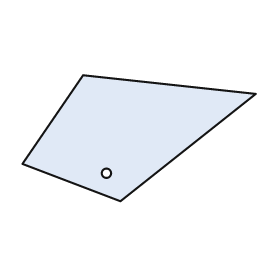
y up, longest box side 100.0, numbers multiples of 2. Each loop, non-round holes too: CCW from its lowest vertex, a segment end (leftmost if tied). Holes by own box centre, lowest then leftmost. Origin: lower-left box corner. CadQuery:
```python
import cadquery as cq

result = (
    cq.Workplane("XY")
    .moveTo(42.0, 0.0)
    .lineTo(100.0, 46.0)
    .lineTo(26.0, 54.0)
    .lineTo(0.0, 16.0)
    .close()
    .moveTo(36.0, 12.0)
    .circle(2.0)
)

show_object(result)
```